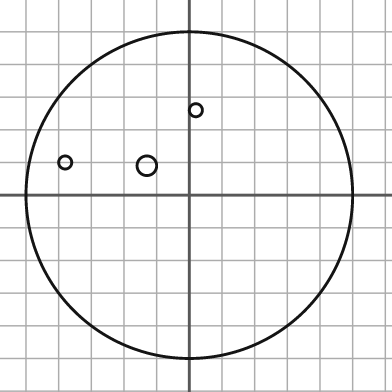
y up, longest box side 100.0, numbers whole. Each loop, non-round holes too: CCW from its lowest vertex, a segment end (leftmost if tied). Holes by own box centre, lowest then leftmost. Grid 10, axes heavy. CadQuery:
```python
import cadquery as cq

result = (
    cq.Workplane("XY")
    .moveTo(0.0, 0.0)
    .circle(50.0)
    .moveTo(-13.0, 9.0)
    .circle(3.0)
    .moveTo(-38.0, 10.0)
    .circle(2.0)
    .moveTo(2.0, 26.0)
    .circle(2.0)
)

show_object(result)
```